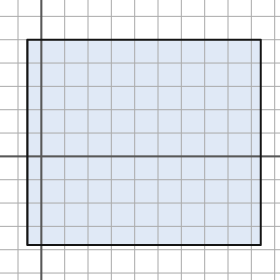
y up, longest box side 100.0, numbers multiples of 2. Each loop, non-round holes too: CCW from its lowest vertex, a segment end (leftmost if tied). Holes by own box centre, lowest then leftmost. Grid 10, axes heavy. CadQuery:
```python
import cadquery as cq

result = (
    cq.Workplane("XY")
    .moveTo(-6.0, -38.0)
    .lineTo(94.0, -38.0)
    .lineTo(94.0, 50.0)
    .lineTo(-6.0, 50.0)
    .close()
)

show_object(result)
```